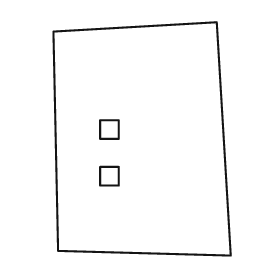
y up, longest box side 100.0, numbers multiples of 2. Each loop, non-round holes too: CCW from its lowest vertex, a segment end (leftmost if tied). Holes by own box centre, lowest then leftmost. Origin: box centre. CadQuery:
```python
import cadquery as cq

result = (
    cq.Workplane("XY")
    .moveTo(38.0, -50.0)
    .lineTo(32.0, 50.0)
    .lineTo(-38.0, 46.0)
    .lineTo(-36.0, -48.0)
    .close()
    .moveTo(-18.0, -20.0)
    .lineTo(-10.0, -20.0)
    .lineTo(-10.0, -12.0)
    .lineTo(-18.0, -12.0)
    .close()
    .moveTo(-18.0, 0.0)
    .lineTo(-10.0, 0.0)
    .lineTo(-10.0, 8.0)
    .lineTo(-18.0, 8.0)
    .close()
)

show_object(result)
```